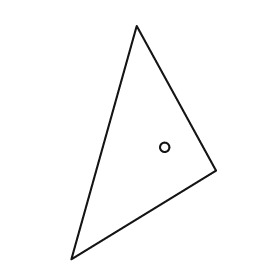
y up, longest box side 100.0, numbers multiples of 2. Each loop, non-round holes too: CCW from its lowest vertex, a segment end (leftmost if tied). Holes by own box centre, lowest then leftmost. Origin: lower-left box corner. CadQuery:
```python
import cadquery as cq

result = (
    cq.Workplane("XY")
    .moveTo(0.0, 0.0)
    .lineTo(62.0, 38.0)
    .lineTo(28.0, 100.0)
    .close()
    .moveTo(40.0, 48.0)
    .circle(2.0)
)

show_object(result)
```